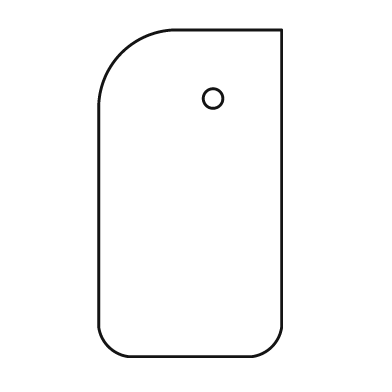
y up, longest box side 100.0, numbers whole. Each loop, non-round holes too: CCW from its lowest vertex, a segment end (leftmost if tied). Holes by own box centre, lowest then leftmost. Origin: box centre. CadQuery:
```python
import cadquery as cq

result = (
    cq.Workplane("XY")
    .moveTo(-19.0, -50.0)
    .lineTo(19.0, -50.0)
    .threePointArc((25.0, -47.0), (28.0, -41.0))
    .lineTo(28.0, 50.0)
    .lineTo(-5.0, 50.0)
    .threePointArc((-21.0, 43.0), (-28.0, 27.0))
    .lineTo(-28.0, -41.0)
    .threePointArc((-25.0, -47.0), (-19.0, -50.0))
    .close()
    .moveTo(7.0, 29.0)
    .circle(3.0)
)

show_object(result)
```